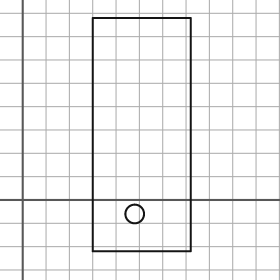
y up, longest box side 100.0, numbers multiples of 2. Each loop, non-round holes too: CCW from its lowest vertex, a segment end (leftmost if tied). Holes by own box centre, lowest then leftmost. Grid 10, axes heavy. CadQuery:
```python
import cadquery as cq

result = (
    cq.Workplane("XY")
    .moveTo(30.0, -22.0)
    .lineTo(72.0, -22.0)
    .lineTo(72.0, 78.0)
    .lineTo(30.0, 78.0)
    .close()
    .moveTo(48.0, -6.0)
    .circle(4.0)
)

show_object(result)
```